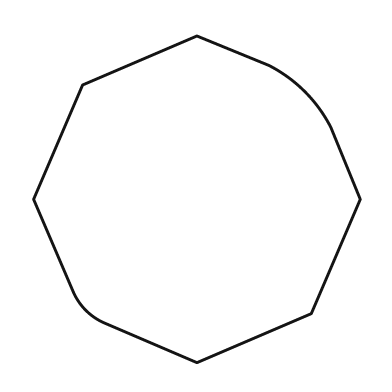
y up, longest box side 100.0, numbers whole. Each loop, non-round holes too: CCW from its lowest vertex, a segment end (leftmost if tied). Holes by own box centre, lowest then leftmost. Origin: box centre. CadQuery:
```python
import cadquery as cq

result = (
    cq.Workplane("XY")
    .moveTo(0.0, -50.0)
    .lineTo(35.0, -35.0)
    .lineTo(50.0, 0.0)
    .lineTo(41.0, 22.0)
    .threePointArc((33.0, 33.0), (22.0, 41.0))
    .lineTo(0.0, 50.0)
    .lineTo(-35.0, 35.0)
    .lineTo(-50.0, 0.0)
    .lineTo(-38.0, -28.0)
    .threePointArc((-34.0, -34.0), (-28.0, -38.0))
    .close()
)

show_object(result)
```